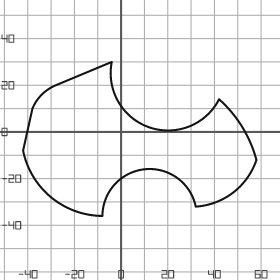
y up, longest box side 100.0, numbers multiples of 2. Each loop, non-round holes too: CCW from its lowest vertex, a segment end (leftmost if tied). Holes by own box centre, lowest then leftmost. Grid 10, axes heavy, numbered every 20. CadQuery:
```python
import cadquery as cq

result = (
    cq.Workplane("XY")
    .moveTo(-8.0, -36.0)
    .threePointArc((10.0, -16.0), (32.0, -32.0))
    .threePointArc((48.0, -26.0), (58.0, -12.0))
    .threePointArc((52.0, 2.0), (42.0, 14.0))
    .threePointArc((12.0, 2.0), (-4.0, 30.0))
    .lineTo(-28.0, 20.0)
    .threePointArc((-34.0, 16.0), (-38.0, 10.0))
    .lineTo(-42.0, -8.0)
    .threePointArc((-30.0, -28.0), (-8.0, -36.0))
    .close()
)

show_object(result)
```